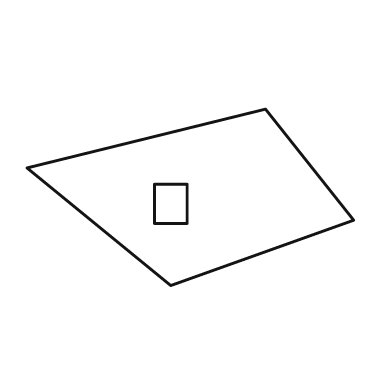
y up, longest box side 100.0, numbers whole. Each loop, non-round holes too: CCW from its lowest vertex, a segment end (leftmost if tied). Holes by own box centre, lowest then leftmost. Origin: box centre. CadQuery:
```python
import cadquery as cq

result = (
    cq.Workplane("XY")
    .moveTo(-6.0, -27.0)
    .lineTo(50.0, -7.0)
    .lineTo(23.0, 27.0)
    .lineTo(-50.0, 9.0)
    .close()
    .moveTo(-11.0, -8.0)
    .lineTo(-1.0, -8.0)
    .lineTo(-1.0, 4.0)
    .lineTo(-11.0, 4.0)
    .close()
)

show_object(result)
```